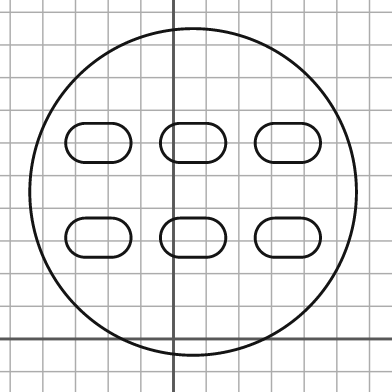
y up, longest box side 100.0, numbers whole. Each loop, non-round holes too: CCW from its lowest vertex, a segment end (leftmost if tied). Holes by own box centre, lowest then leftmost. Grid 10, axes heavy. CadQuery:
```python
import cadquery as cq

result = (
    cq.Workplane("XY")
    .moveTo(6.0, 45.0)
    .circle(50.0)
    .moveTo(-27.0, 25.0)
    .lineTo(-19.0, 25.0)
    .threePointArc((-13.0, 31.0), (-19.0, 37.0))
    .lineTo(-27.0, 37.0)
    .threePointArc((-33.0, 31.0), (-27.0, 25.0))
    .close()
    .moveTo(2.0, 25.0)
    .lineTo(10.0, 25.0)
    .threePointArc((16.0, 31.0), (10.0, 37.0))
    .lineTo(2.0, 37.0)
    .threePointArc((-4.0, 31.0), (2.0, 25.0))
    .close()
    .moveTo(31.0, 25.0)
    .lineTo(39.0, 25.0)
    .threePointArc((45.0, 31.0), (39.0, 37.0))
    .lineTo(31.0, 37.0)
    .threePointArc((25.0, 31.0), (31.0, 25.0))
    .close()
    .moveTo(-27.0, 54.0)
    .lineTo(-19.0, 54.0)
    .threePointArc((-13.0, 60.0), (-19.0, 66.0))
    .lineTo(-27.0, 66.0)
    .threePointArc((-33.0, 60.0), (-27.0, 54.0))
    .close()
    .moveTo(2.0, 54.0)
    .lineTo(10.0, 54.0)
    .threePointArc((16.0, 60.0), (10.0, 66.0))
    .lineTo(2.0, 66.0)
    .threePointArc((-4.0, 60.0), (2.0, 54.0))
    .close()
    .moveTo(31.0, 54.0)
    .lineTo(39.0, 54.0)
    .threePointArc((45.0, 60.0), (39.0, 66.0))
    .lineTo(31.0, 66.0)
    .threePointArc((25.0, 60.0), (31.0, 54.0))
    .close()
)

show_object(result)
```